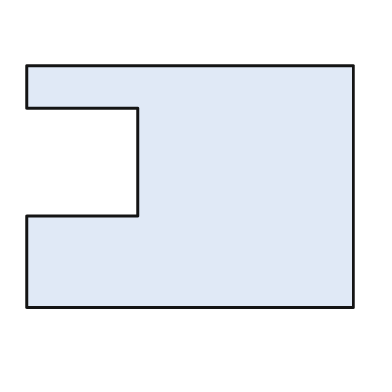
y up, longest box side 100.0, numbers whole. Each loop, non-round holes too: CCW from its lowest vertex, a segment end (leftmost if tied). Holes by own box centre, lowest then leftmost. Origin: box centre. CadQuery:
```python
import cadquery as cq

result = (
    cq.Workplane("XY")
    .moveTo(-50.0, -37.0)
    .lineTo(50.0, -37.0)
    .lineTo(50.0, 37.0)
    .lineTo(-50.0, 37.0)
    .lineTo(-50.0, 24.0)
    .lineTo(-16.0, 24.0)
    .lineTo(-16.0, -9.0)
    .lineTo(-50.0, -9.0)
    .close()
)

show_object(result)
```